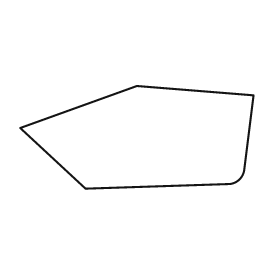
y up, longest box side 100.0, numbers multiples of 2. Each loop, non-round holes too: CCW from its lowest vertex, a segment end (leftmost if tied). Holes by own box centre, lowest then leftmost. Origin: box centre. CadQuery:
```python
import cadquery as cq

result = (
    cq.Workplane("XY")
    .moveTo(-22.0, -22.0)
    .lineTo(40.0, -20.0)
    .threePointArc((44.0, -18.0), (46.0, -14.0))
    .lineTo(50.0, 18.0)
    .lineTo(0.0, 22.0)
    .lineTo(-50.0, 4.0)
    .close()
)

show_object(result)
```